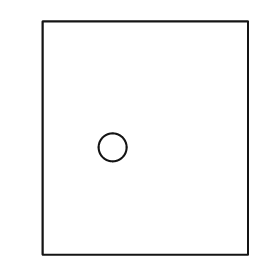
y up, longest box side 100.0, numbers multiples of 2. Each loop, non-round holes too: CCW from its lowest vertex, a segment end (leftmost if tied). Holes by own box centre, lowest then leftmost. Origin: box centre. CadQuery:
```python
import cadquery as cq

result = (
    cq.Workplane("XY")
    .moveTo(-44.0, -50.0)
    .lineTo(44.0, -50.0)
    .lineTo(44.0, 50.0)
    .lineTo(-44.0, 50.0)
    .close()
    .moveTo(-14.0, -4.0)
    .circle(6.0)
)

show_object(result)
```